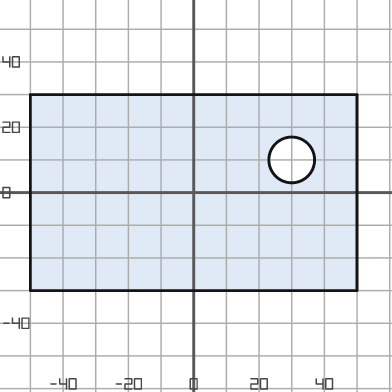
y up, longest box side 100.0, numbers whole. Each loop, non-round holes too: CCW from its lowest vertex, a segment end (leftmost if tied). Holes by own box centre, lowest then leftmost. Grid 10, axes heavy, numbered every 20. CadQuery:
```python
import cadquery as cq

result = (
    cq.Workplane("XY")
    .moveTo(-50.0, -30.0)
    .lineTo(50.0, -30.0)
    .lineTo(50.0, 30.0)
    .lineTo(-50.0, 30.0)
    .close()
    .moveTo(30.0, 10.0)
    .circle(7.0)
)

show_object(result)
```